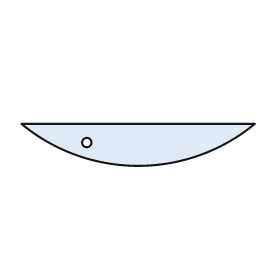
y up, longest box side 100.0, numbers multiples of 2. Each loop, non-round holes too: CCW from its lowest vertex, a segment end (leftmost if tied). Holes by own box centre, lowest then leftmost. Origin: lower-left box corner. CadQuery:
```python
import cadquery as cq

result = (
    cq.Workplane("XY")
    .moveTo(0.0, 18.0)
    .threePointArc((50.0, 0.0), (100.0, 18.0))
    .close()
    .moveTo(28.0, 10.0)
    .circle(2.0)
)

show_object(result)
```